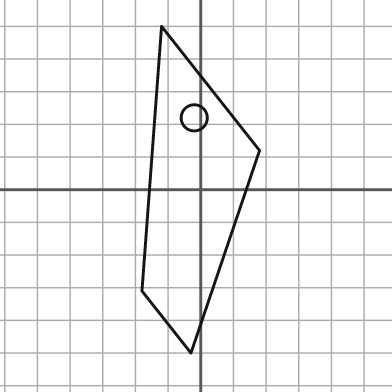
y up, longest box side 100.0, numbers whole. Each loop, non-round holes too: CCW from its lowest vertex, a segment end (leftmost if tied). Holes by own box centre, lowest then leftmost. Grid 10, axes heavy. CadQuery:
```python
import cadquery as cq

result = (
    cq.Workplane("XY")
    .moveTo(-3.0, -50.0)
    .lineTo(18.0, 12.0)
    .lineTo(-12.0, 50.0)
    .lineTo(-18.0, -31.0)
    .close()
    .moveTo(-2.0, 22.0)
    .circle(4.0)
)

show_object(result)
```